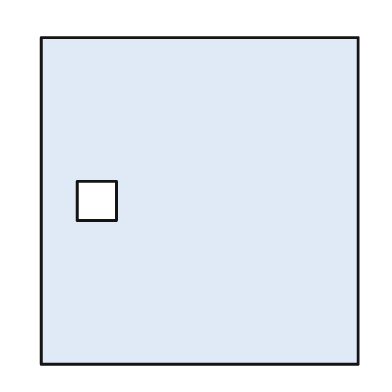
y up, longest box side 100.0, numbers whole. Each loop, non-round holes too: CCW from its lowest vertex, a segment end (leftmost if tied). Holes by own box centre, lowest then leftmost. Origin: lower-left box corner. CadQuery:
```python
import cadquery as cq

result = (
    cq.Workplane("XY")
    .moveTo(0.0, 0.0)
    .lineTo(97.0, 0.0)
    .lineTo(97.0, 100.0)
    .lineTo(0.0, 100.0)
    .close()
    .moveTo(11.0, 44.0)
    .lineTo(23.0, 44.0)
    .lineTo(23.0, 56.0)
    .lineTo(11.0, 56.0)
    .close()
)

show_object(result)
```